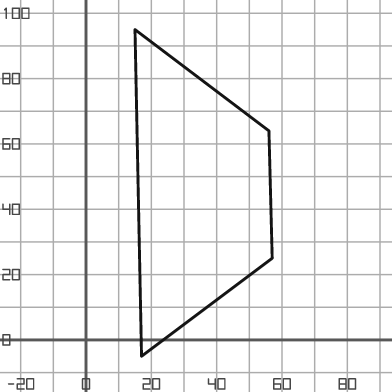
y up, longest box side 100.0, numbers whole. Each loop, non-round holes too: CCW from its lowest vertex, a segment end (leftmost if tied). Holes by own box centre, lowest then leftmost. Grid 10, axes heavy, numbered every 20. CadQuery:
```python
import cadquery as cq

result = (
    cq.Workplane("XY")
    .moveTo(17.0, -5.0)
    .lineTo(57.0, 25.0)
    .lineTo(56.0, 64.0)
    .lineTo(15.0, 95.0)
    .close()
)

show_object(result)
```